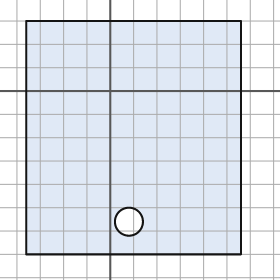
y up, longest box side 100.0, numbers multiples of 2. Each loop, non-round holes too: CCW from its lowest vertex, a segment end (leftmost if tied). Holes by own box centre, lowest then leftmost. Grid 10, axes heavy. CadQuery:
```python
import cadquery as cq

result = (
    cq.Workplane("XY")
    .moveTo(-36.0, -70.0)
    .lineTo(56.0, -70.0)
    .lineTo(56.0, 30.0)
    .lineTo(-36.0, 30.0)
    .close()
    .moveTo(8.0, -56.0)
    .circle(6.0)
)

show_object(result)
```